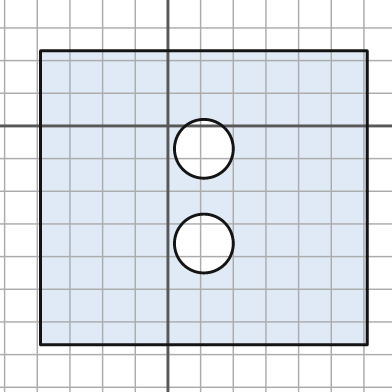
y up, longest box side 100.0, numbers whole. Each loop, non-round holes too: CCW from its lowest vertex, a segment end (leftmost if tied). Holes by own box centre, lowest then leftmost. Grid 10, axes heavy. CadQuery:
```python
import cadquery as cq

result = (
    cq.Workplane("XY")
    .moveTo(-39.0, -67.0)
    .lineTo(61.0, -67.0)
    .lineTo(61.0, 23.0)
    .lineTo(-39.0, 23.0)
    .close()
    .moveTo(11.0, -36.0)
    .circle(9.0)
    .moveTo(11.0, -7.0)
    .circle(9.0)
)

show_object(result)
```